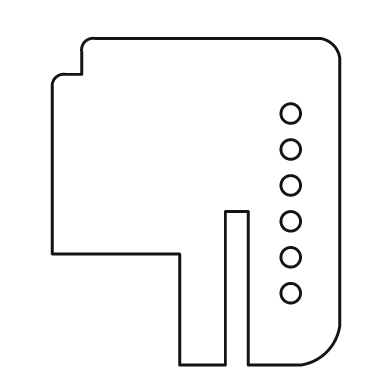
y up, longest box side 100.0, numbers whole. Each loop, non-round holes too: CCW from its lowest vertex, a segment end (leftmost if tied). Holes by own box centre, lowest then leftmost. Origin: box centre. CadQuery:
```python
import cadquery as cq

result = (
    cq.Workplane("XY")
    .moveTo(-5.0, -50.0)
    .lineTo(9.0, -50.0)
    .lineTo(9.0, -3.0)
    .lineTo(16.0, -3.0)
    .lineTo(16.0, -50.0)
    .lineTo(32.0, -50.0)
    .threePointArc((40.0, -46.0), (44.0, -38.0))
    .lineTo(44.0, 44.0)
    .threePointArc((42.0, 48.0), (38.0, 50.0))
    .lineTo(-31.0, 50.0)
    .threePointArc((-34.0, 49.0), (-35.0, 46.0))
    .lineTo(-35.0, 39.0)
    .lineTo(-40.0, 39.0)
    .threePointArc((-43.0, 38.0), (-44.0, 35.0))
    .lineTo(-44.0, -16.0)
    .lineTo(-5.0, -16.0)
    .close()
    .moveTo(29.0, -28.0)
    .circle(3.0)
    .moveTo(29.0, -17.0)
    .circle(3.0)
    .moveTo(29.0, -6.0)
    .circle(3.0)
    .moveTo(29.0, 5.0)
    .circle(3.0)
    .moveTo(29.0, 16.0)
    .circle(3.0)
    .moveTo(29.0, 27.0)
    .circle(3.0)
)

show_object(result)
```